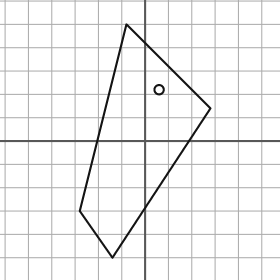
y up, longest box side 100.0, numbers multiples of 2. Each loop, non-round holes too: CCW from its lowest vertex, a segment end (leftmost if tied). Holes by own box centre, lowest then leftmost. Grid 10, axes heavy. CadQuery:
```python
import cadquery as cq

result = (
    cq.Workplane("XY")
    .moveTo(-14.0, -50.0)
    .lineTo(28.0, 14.0)
    .lineTo(-8.0, 50.0)
    .lineTo(-28.0, -30.0)
    .close()
    .moveTo(6.0, 22.0)
    .circle(2.0)
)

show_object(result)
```